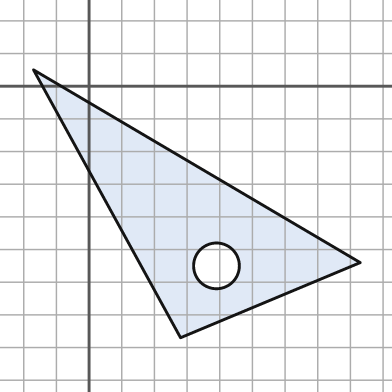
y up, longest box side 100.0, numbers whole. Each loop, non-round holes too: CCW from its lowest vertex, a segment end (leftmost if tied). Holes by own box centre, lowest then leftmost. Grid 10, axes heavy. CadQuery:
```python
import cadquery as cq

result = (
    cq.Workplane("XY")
    .moveTo(28.0, -77.0)
    .lineTo(83.0, -54.0)
    .lineTo(-17.0, 5.0)
    .close()
    .moveTo(39.0, -55.0)
    .circle(7.0)
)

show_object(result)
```